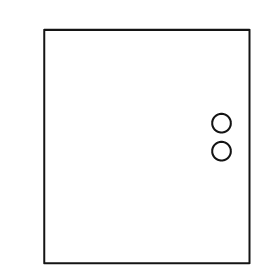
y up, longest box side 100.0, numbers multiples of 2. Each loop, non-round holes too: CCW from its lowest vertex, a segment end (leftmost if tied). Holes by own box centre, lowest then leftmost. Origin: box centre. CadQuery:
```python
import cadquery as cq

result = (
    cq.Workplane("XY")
    .moveTo(-44.0, -50.0)
    .lineTo(44.0, -50.0)
    .lineTo(44.0, 50.0)
    .lineTo(-44.0, 50.0)
    .close()
    .moveTo(32.0, -2.0)
    .circle(4.0)
    .moveTo(32.0, 10.0)
    .circle(4.0)
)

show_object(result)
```